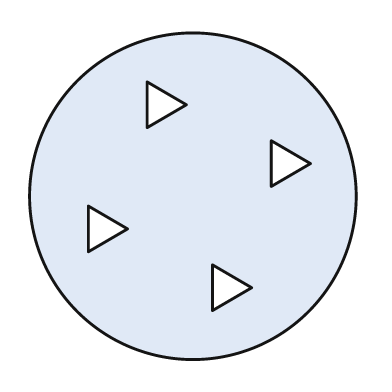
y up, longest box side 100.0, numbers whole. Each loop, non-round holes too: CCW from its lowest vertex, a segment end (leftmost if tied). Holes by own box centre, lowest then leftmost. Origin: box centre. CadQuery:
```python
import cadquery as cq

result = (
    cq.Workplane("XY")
    .moveTo(0.0, 0.0)
    .circle(50.0)
    .moveTo(6.0, -35.0)
    .lineTo(18.0, -28.0)
    .lineTo(6.0, -21.0)
    .close()
    .moveTo(-32.0, -17.0)
    .lineTo(-20.0, -10.0)
    .lineTo(-32.0, -3.0)
    .close()
    .moveTo(24.0, 3.0)
    .lineTo(36.0, 10.0)
    .lineTo(24.0, 17.0)
    .close()
    .moveTo(-14.0, 21.0)
    .lineTo(-2.0, 28.0)
    .lineTo(-14.0, 35.0)
    .close()
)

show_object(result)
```